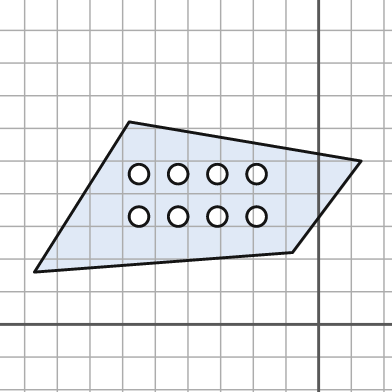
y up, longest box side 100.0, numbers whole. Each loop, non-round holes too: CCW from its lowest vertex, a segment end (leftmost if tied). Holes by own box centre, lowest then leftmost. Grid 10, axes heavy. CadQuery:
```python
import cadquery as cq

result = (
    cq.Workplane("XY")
    .moveTo(-87.0, 16.0)
    .lineTo(-8.0, 22.0)
    .lineTo(13.0, 50.0)
    .lineTo(-58.0, 62.0)
    .close()
    .moveTo(-55.0, 33.0)
    .circle(3.0)
    .moveTo(-43.0, 33.0)
    .circle(3.0)
    .moveTo(-31.0, 33.0)
    .circle(3.0)
    .moveTo(-19.0, 33.0)
    .circle(3.0)
    .moveTo(-55.0, 46.0)
    .circle(3.0)
    .moveTo(-43.0, 46.0)
    .circle(3.0)
    .moveTo(-31.0, 46.0)
    .circle(3.0)
    .moveTo(-19.0, 46.0)
    .circle(3.0)
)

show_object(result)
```